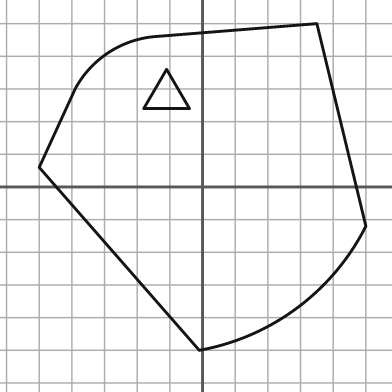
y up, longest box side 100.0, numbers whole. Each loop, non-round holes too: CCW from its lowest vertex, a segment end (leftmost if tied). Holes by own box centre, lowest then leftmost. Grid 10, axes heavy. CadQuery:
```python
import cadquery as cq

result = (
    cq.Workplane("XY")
    .moveTo(-1.0, -50.0)
    .threePointArc((29.0, -37.0), (50.0, -12.0))
    .lineTo(35.0, 50.0)
    .lineTo(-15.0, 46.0)
    .threePointArc((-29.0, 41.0), (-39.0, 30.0))
    .lineTo(-50.0, 6.0)
    .close()
    .moveTo(-18.0, 24.0)
    .lineTo(-4.0, 24.0)
    .lineTo(-11.0, 36.0)
    .close()
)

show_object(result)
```